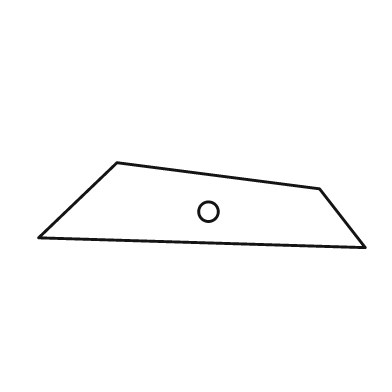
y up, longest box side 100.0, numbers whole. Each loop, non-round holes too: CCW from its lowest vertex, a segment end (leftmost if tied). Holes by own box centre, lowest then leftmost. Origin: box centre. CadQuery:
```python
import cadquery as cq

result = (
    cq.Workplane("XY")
    .moveTo(50.0, -13.0)
    .lineTo(36.0, 5.0)
    .lineTo(-26.0, 13.0)
    .lineTo(-50.0, -10.0)
    .close()
    .moveTo(2.0, -2.0)
    .circle(3.0)
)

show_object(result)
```